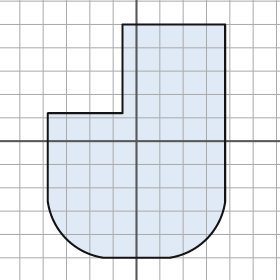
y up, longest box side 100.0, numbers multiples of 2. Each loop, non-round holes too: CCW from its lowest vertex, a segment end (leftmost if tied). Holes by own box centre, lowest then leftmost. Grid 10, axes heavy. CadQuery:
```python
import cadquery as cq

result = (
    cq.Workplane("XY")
    .moveTo(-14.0, -50.0)
    .lineTo(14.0, -50.0)
    .threePointArc((30.0, -42.0), (38.0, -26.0))
    .lineTo(38.0, 50.0)
    .lineTo(-6.0, 50.0)
    .lineTo(-6.0, 12.0)
    .lineTo(-38.0, 12.0)
    .lineTo(-38.0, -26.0)
    .threePointArc((-30.0, -42.0), (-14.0, -50.0))
    .close()
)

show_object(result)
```